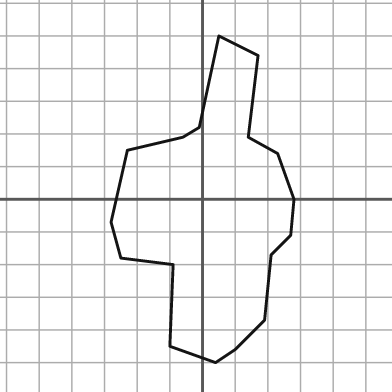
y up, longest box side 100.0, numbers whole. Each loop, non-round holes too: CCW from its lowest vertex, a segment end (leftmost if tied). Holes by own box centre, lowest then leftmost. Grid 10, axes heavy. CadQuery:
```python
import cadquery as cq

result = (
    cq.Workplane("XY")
    .moveTo(4.0, -50.0)
    .lineTo(10.0, -46.0)
    .lineTo(19.0, -37.0)
    .lineTo(21.0, -17.0)
    .lineTo(27.0, -11.0)
    .lineTo(28.0, 0.0)
    .lineTo(23.0, 14.0)
    .lineTo(14.0, 19.0)
    .lineTo(17.0, 44.0)
    .lineTo(5.0, 50.0)
    .lineTo(-1.0, 22.0)
    .lineTo(-6.0, 19.0)
    .lineTo(-23.0, 15.0)
    .lineTo(-28.0, -7.0)
    .lineTo(-25.0, -18.0)
    .lineTo(-9.0, -20.0)
    .lineTo(-10.0, -45.0)
    .close()
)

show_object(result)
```